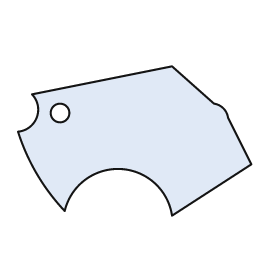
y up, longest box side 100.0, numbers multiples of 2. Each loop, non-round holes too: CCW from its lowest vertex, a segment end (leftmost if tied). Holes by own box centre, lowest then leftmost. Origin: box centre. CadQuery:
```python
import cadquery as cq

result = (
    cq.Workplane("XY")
    .moveTo(16.0, -32.0)
    .lineTo(50.0, -10.0)
    .lineTo(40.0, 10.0)
    .threePointArc((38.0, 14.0), (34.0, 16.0))
    .lineTo(16.0, 32.0)
    .lineTo(-44.0, 20.0)
    .threePointArc((-42.0, 10.0), (-50.0, 4.0))
    .threePointArc((-42.0, -14.0), (-30.0, -30.0))
    .threePointArc((-6.0, -12.0), (16.0, -32.0))
    .close()
    .moveTo(-32.0, 12.0)
    .circle(4.0)
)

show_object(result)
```